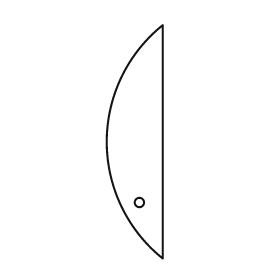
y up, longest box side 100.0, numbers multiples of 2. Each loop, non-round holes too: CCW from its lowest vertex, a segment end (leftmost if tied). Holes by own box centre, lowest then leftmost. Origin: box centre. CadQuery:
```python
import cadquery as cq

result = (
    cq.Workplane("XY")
    .moveTo(12.0, -50.0)
    .lineTo(12.0, 50.0)
    .threePointArc((-12.0, 0.0), (12.0, -50.0))
    .close()
    .moveTo(2.0, -26.0)
    .circle(2.0)
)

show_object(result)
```